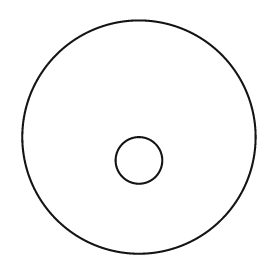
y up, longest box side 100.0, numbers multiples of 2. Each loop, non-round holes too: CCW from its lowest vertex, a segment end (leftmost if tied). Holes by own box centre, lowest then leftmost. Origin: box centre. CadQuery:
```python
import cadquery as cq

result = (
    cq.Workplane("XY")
    .moveTo(0.0, 0.0)
    .circle(50.0)
    .moveTo(0.0, -10.0)
    .circle(10.0)
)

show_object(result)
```